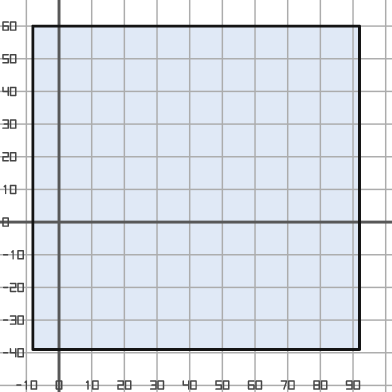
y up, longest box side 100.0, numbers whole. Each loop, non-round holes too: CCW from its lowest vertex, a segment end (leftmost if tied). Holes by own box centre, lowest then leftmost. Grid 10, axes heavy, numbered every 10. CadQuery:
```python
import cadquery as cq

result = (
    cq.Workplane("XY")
    .moveTo(-8.0, -39.0)
    .lineTo(92.0, -39.0)
    .lineTo(92.0, 60.0)
    .lineTo(-8.0, 60.0)
    .close()
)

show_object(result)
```